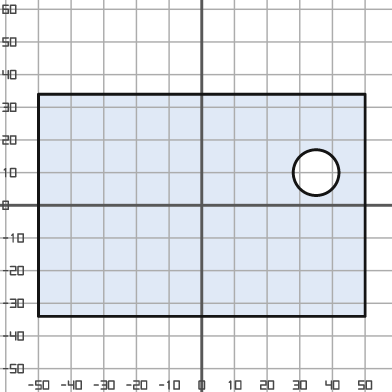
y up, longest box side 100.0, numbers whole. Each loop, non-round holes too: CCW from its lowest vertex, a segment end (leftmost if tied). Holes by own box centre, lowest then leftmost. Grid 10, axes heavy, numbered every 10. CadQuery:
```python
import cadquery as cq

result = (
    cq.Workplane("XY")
    .moveTo(-50.0, -34.0)
    .lineTo(50.0, -34.0)
    .lineTo(50.0, 34.0)
    .lineTo(-50.0, 34.0)
    .close()
    .moveTo(35.0, 10.0)
    .circle(7.0)
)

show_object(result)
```